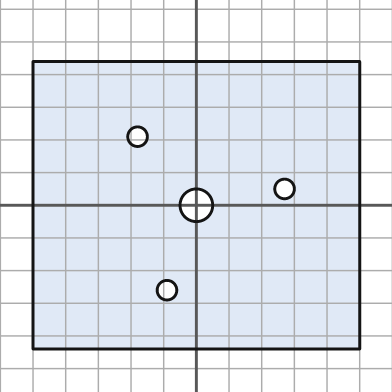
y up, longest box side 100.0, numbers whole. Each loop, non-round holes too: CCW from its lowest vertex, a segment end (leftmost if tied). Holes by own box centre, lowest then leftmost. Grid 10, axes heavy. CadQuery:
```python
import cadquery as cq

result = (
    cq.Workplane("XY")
    .moveTo(-50.0, -44.0)
    .lineTo(50.0, -44.0)
    .lineTo(50.0, 44.0)
    .lineTo(-50.0, 44.0)
    .close()
    .moveTo(-9.0, -26.0)
    .circle(3.0)
    .moveTo(0.0, 0.0)
    .circle(5.0)
    .moveTo(27.0, 5.0)
    .circle(3.0)
    .moveTo(-18.0, 21.0)
    .circle(3.0)
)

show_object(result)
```